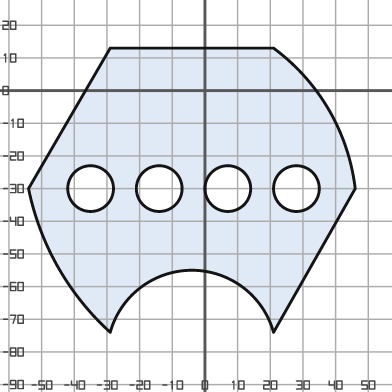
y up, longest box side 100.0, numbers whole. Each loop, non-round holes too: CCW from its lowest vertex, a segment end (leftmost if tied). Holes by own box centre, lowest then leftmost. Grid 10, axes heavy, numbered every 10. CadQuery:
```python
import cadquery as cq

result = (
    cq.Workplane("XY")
    .moveTo(-29.0, -74.0)
    .threePointArc((-4.0, -55.0), (21.0, -74.0))
    .lineTo(46.0, -30.0)
    .threePointArc((38.0, -6.0), (21.0, 13.0))
    .lineTo(-29.0, 13.0)
    .lineTo(-54.0, -30.0)
    .threePointArc((-45.0, -54.0), (-29.0, -74.0))
    .close()
    .moveTo(-35.0, -30.0)
    .circle(7.0)
    .moveTo(-14.0, -30.0)
    .circle(7.0)
    .moveTo(7.0, -30.0)
    .circle(7.0)
    .moveTo(28.0, -30.0)
    .circle(7.0)
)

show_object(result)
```